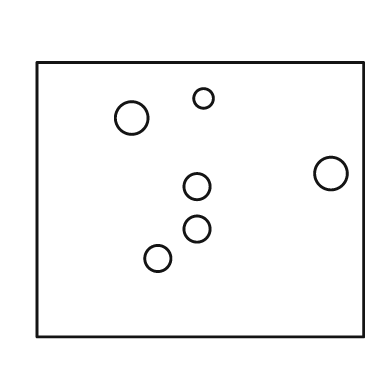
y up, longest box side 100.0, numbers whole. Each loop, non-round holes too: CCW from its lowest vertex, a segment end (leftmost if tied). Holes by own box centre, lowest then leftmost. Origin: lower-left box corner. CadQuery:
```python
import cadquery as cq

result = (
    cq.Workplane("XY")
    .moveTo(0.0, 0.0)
    .lineTo(100.0, 0.0)
    .lineTo(100.0, 84.0)
    .lineTo(0.0, 84.0)
    .close()
    .moveTo(37.0, 24.0)
    .circle(4.0)
    .moveTo(49.0, 33.0)
    .circle(4.0)
    .moveTo(49.0, 46.0)
    .circle(4.0)
    .moveTo(90.0, 50.0)
    .circle(5.0)
    .moveTo(29.0, 67.0)
    .circle(5.0)
    .moveTo(51.0, 73.0)
    .circle(3.0)
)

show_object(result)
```